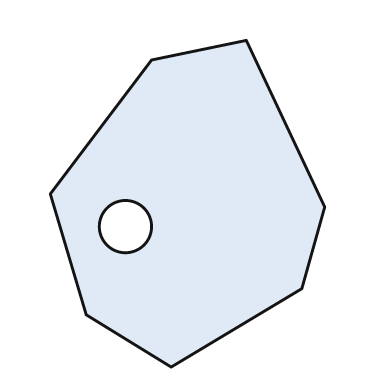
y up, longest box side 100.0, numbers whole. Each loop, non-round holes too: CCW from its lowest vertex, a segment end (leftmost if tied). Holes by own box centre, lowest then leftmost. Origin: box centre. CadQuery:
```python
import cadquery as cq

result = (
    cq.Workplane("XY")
    .moveTo(-5.0, -50.0)
    .lineTo(35.0, -26.0)
    .lineTo(42.0, -1.0)
    .lineTo(18.0, 50.0)
    .lineTo(-11.0, 44.0)
    .lineTo(-42.0, 3.0)
    .lineTo(-31.0, -34.0)
    .close()
    .moveTo(-19.0, -7.0)
    .circle(8.0)
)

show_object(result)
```